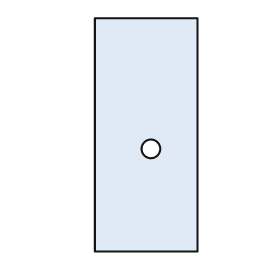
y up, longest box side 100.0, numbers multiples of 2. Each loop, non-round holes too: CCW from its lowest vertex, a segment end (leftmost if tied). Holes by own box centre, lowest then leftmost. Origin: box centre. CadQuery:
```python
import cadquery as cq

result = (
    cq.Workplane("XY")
    .moveTo(-22.0, -50.0)
    .lineTo(22.0, -50.0)
    .lineTo(22.0, 50.0)
    .lineTo(-22.0, 50.0)
    .close()
    .moveTo(2.0, -6.0)
    .circle(4.0)
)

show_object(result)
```